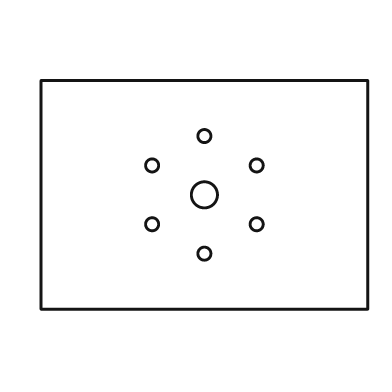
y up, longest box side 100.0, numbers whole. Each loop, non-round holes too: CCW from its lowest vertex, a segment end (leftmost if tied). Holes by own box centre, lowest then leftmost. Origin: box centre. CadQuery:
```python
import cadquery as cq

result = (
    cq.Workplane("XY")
    .moveTo(-50.0, -35.0)
    .lineTo(50.0, -35.0)
    .lineTo(50.0, 35.0)
    .lineTo(-50.0, 35.0)
    .close()
    .moveTo(0.0, -18.0)
    .circle(2.0)
    .moveTo(-16.0, -9.0)
    .circle(2.0)
    .moveTo(16.0, -9.0)
    .circle(2.0)
    .moveTo(0.0, 0.0)
    .circle(4.0)
    .moveTo(-16.0, 9.0)
    .circle(2.0)
    .moveTo(16.0, 9.0)
    .circle(2.0)
    .moveTo(0.0, 18.0)
    .circle(2.0)
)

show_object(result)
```